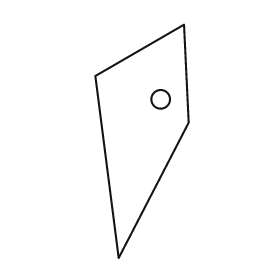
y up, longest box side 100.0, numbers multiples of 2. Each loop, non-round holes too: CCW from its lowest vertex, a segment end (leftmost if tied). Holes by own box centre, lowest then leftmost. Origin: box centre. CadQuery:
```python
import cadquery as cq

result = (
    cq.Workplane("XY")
    .moveTo(-10.0, -50.0)
    .lineTo(20.0, 8.0)
    .lineTo(18.0, 50.0)
    .lineTo(-20.0, 28.0)
    .close()
    .moveTo(8.0, 18.0)
    .circle(4.0)
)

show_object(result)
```